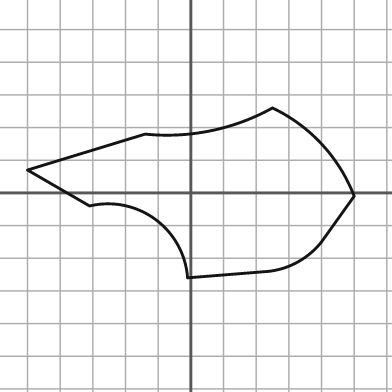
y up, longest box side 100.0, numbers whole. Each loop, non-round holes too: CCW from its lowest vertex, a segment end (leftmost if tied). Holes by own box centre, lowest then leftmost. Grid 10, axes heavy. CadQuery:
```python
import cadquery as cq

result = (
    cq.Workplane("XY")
    .moveTo(-1.0, -26.0)
    .lineTo(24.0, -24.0)
    .threePointArc((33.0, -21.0), (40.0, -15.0))
    .lineTo(50.0, -1.0)
    .threePointArc((40.0, 15.0), (25.0, 26.0))
    .threePointArc((6.0, 19.0), (-14.0, 18.0))
    .lineTo(-50.0, 7.0)
    .lineTo(-31.0, -4.0)
    .threePointArc((-11.0, -8.0), (-1.0, -26.0))
    .close()
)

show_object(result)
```